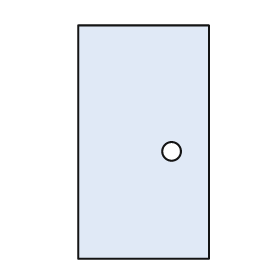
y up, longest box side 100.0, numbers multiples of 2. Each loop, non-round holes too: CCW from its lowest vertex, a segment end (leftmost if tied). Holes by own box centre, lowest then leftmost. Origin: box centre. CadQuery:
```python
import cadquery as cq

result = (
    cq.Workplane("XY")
    .moveTo(-28.0, -50.0)
    .lineTo(28.0, -50.0)
    .lineTo(28.0, 50.0)
    .lineTo(-28.0, 50.0)
    .close()
    .moveTo(12.0, -4.0)
    .circle(4.0)
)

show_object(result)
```